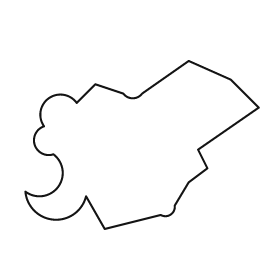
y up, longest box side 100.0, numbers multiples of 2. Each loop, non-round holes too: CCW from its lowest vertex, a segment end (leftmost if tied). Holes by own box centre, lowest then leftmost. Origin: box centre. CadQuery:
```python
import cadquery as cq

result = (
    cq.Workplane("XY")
    .moveTo(-16.0, -36.0)
    .lineTo(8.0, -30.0)
    .threePointArc((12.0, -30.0), (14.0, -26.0))
    .lineTo(20.0, -16.0)
    .lineTo(28.0, -10.0)
    .lineTo(24.0, -2.0)
    .lineTo(50.0, 16.0)
    .lineTo(38.0, 28.0)
    .lineTo(20.0, 36.0)
    .lineTo(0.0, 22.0)
    .threePointArc((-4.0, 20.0), (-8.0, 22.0))
    .lineTo(-20.0, 26.0)
    .lineTo(-28.0, 18.0)
    .threePointArc((-40.0, 20.0), (-42.0, 8.0))
    .threePointArc((-46.0, 0.0), (-38.0, -4.0))
    .threePointArc((-36.0, -18.0), (-50.0, -20.0))
    .threePointArc((-38.0, -32.0), (-24.0, -22.0))
    .close()
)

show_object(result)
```